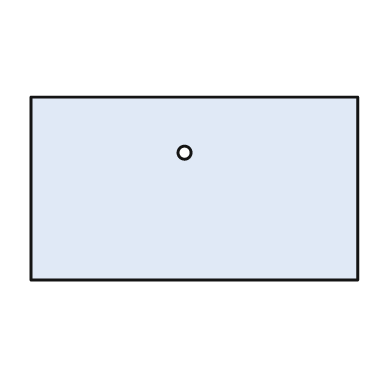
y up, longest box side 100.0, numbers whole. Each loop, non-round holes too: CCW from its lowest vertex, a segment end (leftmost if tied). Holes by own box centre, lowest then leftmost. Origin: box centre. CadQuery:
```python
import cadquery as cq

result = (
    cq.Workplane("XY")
    .moveTo(-50.0, -28.0)
    .lineTo(50.0, -28.0)
    .lineTo(50.0, 28.0)
    .lineTo(-50.0, 28.0)
    .close()
    .moveTo(-3.0, 11.0)
    .circle(2.0)
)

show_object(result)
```